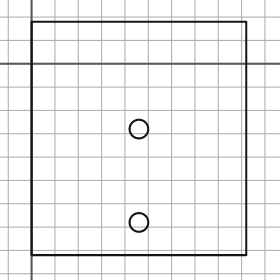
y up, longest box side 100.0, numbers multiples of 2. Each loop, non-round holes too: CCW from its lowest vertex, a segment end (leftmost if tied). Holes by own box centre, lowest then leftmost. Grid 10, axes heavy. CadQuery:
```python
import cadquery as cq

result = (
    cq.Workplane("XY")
    .moveTo(0.0, -82.0)
    .lineTo(92.0, -82.0)
    .lineTo(92.0, 18.0)
    .lineTo(0.0, 18.0)
    .close()
    .moveTo(46.0, -68.0)
    .circle(4.0)
    .moveTo(46.0, -28.0)
    .circle(4.0)
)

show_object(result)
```